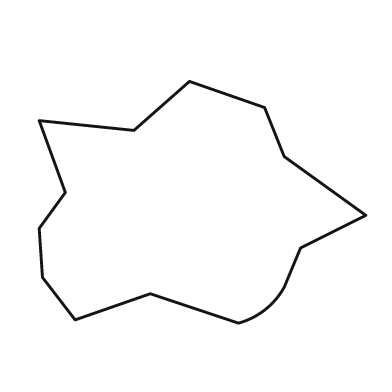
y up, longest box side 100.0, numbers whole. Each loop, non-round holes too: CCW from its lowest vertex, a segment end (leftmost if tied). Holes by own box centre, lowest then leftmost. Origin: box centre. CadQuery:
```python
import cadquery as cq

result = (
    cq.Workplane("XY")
    .moveTo(11.0, -37.0)
    .threePointArc((19.0, -33.0), (25.0, -26.0))
    .lineTo(30.0, -14.0)
    .lineTo(50.0, -4.0)
    .lineTo(25.0, 14.0)
    .lineTo(19.0, 29.0)
    .lineTo(-4.0, 37.0)
    .lineTo(-21.0, 22.0)
    .lineTo(-50.0, 25.0)
    .lineTo(-42.0, 3.0)
    .lineTo(-50.0, -8.0)
    .lineTo(-49.0, -23.0)
    .lineTo(-39.0, -36.0)
    .lineTo(-16.0, -28.0)
    .close()
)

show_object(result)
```